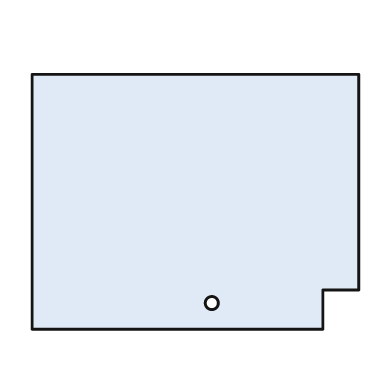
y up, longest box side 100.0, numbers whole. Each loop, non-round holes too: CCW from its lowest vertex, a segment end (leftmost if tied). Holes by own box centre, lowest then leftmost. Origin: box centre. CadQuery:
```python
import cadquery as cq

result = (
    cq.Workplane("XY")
    .moveTo(-50.0, -39.0)
    .lineTo(39.0, -39.0)
    .lineTo(39.0, -27.0)
    .lineTo(50.0, -27.0)
    .lineTo(50.0, 39.0)
    .lineTo(-50.0, 39.0)
    .close()
    .moveTo(5.0, -31.0)
    .circle(2.0)
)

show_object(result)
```